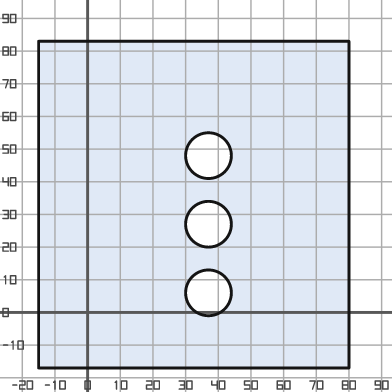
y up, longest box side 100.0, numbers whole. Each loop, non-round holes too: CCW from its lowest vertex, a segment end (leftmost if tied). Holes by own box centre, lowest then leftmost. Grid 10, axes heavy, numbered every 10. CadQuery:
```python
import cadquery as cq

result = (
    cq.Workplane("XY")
    .moveTo(-15.0, -17.0)
    .lineTo(80.0, -17.0)
    .lineTo(80.0, 83.0)
    .lineTo(-15.0, 83.0)
    .close()
    .moveTo(37.0, 6.0)
    .circle(7.0)
    .moveTo(37.0, 27.0)
    .circle(7.0)
    .moveTo(37.0, 48.0)
    .circle(7.0)
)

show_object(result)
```